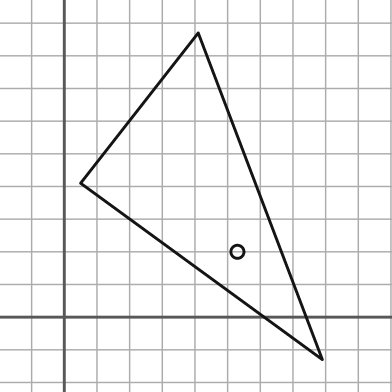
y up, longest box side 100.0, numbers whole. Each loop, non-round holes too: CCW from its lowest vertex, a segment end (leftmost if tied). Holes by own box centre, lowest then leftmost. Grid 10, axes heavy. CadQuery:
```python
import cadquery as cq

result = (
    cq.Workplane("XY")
    .moveTo(79.0, -13.0)
    .lineTo(41.0, 87.0)
    .lineTo(5.0, 41.0)
    .close()
    .moveTo(53.0, 20.0)
    .circle(2.0)
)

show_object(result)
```